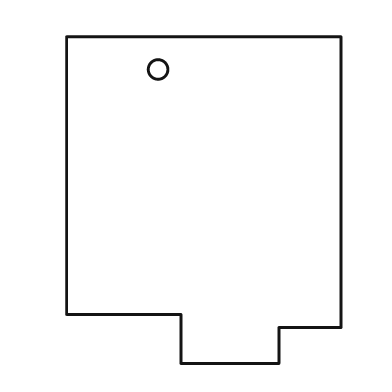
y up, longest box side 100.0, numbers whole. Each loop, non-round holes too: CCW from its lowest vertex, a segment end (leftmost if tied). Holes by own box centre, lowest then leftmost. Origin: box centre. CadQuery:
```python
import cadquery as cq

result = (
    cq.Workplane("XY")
    .moveTo(-7.0, -50.0)
    .lineTo(23.0, -50.0)
    .lineTo(23.0, -39.0)
    .lineTo(42.0, -39.0)
    .lineTo(42.0, 50.0)
    .lineTo(-42.0, 50.0)
    .lineTo(-42.0, -35.0)
    .lineTo(-7.0, -35.0)
    .close()
    .moveTo(-14.0, 40.0)
    .circle(3.0)
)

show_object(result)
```